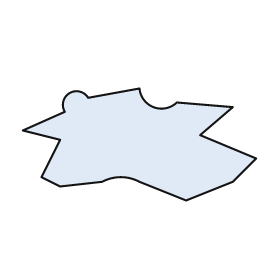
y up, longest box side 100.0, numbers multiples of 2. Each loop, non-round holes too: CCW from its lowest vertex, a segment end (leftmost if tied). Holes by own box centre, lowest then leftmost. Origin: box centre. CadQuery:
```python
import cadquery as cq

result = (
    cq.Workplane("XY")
    .moveTo(20.0, -24.0)
    .lineTo(40.0, -16.0)
    .lineTo(50.0, -6.0)
    .lineTo(26.0, 4.0)
    .lineTo(40.0, 16.0)
    .lineTo(16.0, 18.0)
    .threePointArc((6.0, 16.0), (0.0, 24.0))
    .lineTo(-22.0, 20.0)
    .threePointArc((-30.0, 22.0), (-32.0, 14.0))
    .lineTo(-50.0, 6.0)
    .lineTo(-34.0, 2.0)
    .lineTo(-42.0, -14.0)
    .lineTo(-34.0, -18.0)
    .lineTo(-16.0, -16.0)
    .threePointArc((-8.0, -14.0), (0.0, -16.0))
    .close()
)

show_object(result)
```